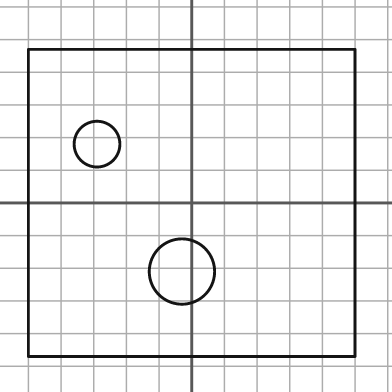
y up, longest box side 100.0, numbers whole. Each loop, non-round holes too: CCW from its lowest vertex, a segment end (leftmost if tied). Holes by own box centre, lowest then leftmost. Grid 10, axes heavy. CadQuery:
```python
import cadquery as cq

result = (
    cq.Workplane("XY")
    .moveTo(-50.0, -47.0)
    .lineTo(50.0, -47.0)
    .lineTo(50.0, 47.0)
    .lineTo(-50.0, 47.0)
    .close()
    .moveTo(-3.0, -21.0)
    .circle(10.0)
    .moveTo(-29.0, 18.0)
    .circle(7.0)
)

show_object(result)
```